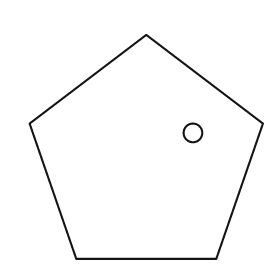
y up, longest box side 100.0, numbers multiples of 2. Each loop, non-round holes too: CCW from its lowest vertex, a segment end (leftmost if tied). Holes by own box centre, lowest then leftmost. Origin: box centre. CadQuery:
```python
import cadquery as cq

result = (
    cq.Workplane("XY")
    .moveTo(-30.0, -48.0)
    .lineTo(30.0, -48.0)
    .lineTo(50.0, 10.0)
    .lineTo(0.0, 48.0)
    .lineTo(-50.0, 10.0)
    .close()
    .moveTo(20.0, 6.0)
    .circle(4.0)
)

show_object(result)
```